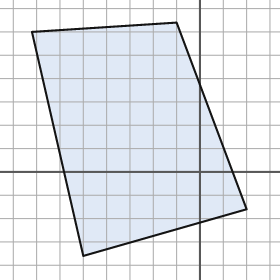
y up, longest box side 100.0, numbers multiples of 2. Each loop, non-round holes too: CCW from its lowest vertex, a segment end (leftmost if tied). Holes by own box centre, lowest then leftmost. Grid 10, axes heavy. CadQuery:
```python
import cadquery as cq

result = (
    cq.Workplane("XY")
    .moveTo(-50.0, -36.0)
    .lineTo(20.0, -16.0)
    .lineTo(-10.0, 64.0)
    .lineTo(-72.0, 60.0)
    .close()
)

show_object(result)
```